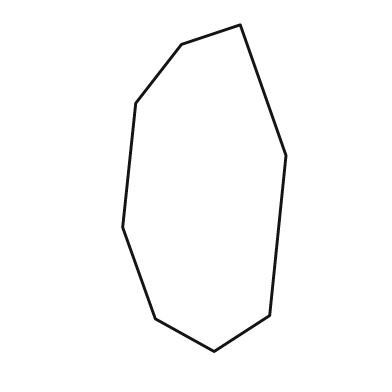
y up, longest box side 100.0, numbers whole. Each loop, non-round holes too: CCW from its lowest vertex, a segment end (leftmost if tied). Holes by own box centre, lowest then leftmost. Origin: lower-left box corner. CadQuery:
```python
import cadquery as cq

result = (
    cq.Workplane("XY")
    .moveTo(28.0, 0.0)
    .lineTo(45.0, 11.0)
    .lineTo(50.0, 60.0)
    .lineTo(36.0, 100.0)
    .lineTo(18.0, 94.0)
    .lineTo(4.0, 76.0)
    .lineTo(0.0, 38.0)
    .lineTo(10.0, 10.0)
    .close()
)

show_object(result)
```